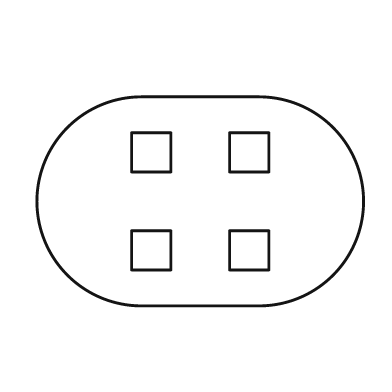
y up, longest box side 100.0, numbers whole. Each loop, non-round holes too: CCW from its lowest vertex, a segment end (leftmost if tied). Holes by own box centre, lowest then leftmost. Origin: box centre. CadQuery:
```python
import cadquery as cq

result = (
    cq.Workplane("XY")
    .moveTo(-18.0, -32.0)
    .lineTo(18.0, -32.0)
    .threePointArc((50.0, 0.0), (18.0, 32.0))
    .lineTo(-18.0, 32.0)
    .threePointArc((-50.0, 0.0), (-18.0, -32.0))
    .close()
    .moveTo(-21.0, -21.0)
    .lineTo(-9.0, -21.0)
    .lineTo(-9.0, -9.0)
    .lineTo(-21.0, -9.0)
    .close()
    .moveTo(9.0, -21.0)
    .lineTo(21.0, -21.0)
    .lineTo(21.0, -9.0)
    .lineTo(9.0, -9.0)
    .close()
    .moveTo(-21.0, 9.0)
    .lineTo(-9.0, 9.0)
    .lineTo(-9.0, 21.0)
    .lineTo(-21.0, 21.0)
    .close()
    .moveTo(9.0, 9.0)
    .lineTo(21.0, 9.0)
    .lineTo(21.0, 21.0)
    .lineTo(9.0, 21.0)
    .close()
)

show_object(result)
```